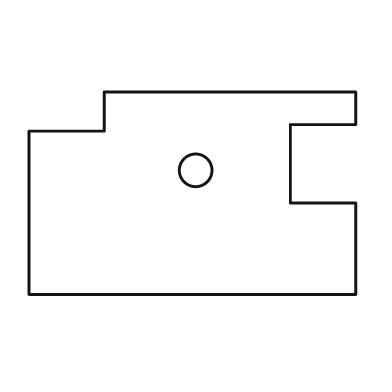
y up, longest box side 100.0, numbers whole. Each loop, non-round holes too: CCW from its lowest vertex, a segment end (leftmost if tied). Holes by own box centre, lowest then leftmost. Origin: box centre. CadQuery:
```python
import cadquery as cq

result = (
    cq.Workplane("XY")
    .moveTo(-50.0, -31.0)
    .lineTo(50.0, -31.0)
    .lineTo(50.0, -3.0)
    .lineTo(30.0, -3.0)
    .lineTo(30.0, 21.0)
    .lineTo(50.0, 21.0)
    .lineTo(50.0, 31.0)
    .lineTo(-27.0, 31.0)
    .lineTo(-27.0, 19.0)
    .lineTo(-50.0, 19.0)
    .close()
    .moveTo(1.0, 7.0)
    .circle(5.0)
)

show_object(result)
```